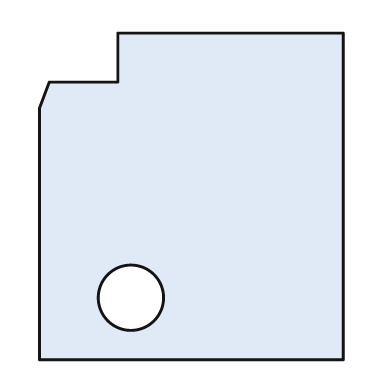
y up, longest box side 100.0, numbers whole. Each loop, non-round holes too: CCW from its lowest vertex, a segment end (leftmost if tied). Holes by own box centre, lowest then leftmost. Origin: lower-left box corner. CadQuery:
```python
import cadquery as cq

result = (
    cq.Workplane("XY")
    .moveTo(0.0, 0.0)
    .lineTo(93.0, 0.0)
    .lineTo(93.0, 100.0)
    .lineTo(24.0, 100.0)
    .lineTo(24.0, 85.0)
    .lineTo(3.0, 85.0)
    .lineTo(0.0, 77.0)
    .close()
    .moveTo(28.0, 19.0)
    .circle(10.0)
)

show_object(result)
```